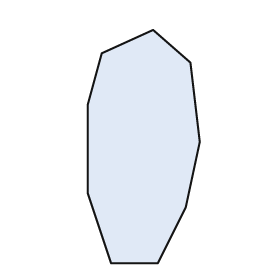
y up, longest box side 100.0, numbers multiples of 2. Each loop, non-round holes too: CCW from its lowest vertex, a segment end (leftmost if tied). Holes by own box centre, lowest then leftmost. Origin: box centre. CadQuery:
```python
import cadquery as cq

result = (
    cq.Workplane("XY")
    .moveTo(-14.0, -50.0)
    .lineTo(6.0, -50.0)
    .lineTo(18.0, -26.0)
    .lineTo(24.0, 2.0)
    .lineTo(20.0, 36.0)
    .lineTo(4.0, 50.0)
    .lineTo(-18.0, 40.0)
    .lineTo(-24.0, 18.0)
    .lineTo(-24.0, -20.0)
    .close()
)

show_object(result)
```